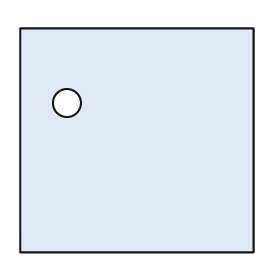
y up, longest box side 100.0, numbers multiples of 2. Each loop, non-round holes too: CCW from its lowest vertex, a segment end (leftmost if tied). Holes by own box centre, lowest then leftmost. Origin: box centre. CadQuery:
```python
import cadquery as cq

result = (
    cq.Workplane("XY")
    .moveTo(-50.0, -48.0)
    .lineTo(50.0, -48.0)
    .lineTo(50.0, 48.0)
    .lineTo(-50.0, 48.0)
    .close()
    .moveTo(-30.0, 16.0)
    .circle(6.0)
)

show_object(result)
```